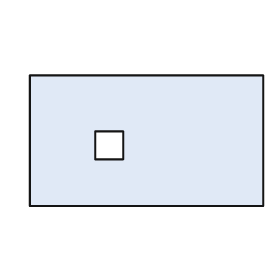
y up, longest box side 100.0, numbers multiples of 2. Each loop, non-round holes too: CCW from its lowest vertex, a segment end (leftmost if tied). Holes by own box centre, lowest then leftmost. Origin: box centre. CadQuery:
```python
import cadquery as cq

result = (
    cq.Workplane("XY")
    .moveTo(-50.0, -28.0)
    .lineTo(50.0, -28.0)
    .lineTo(50.0, 28.0)
    .lineTo(-50.0, 28.0)
    .close()
    .moveTo(-22.0, -8.0)
    .lineTo(-10.0, -8.0)
    .lineTo(-10.0, 4.0)
    .lineTo(-22.0, 4.0)
    .close()
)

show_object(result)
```